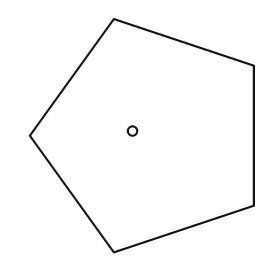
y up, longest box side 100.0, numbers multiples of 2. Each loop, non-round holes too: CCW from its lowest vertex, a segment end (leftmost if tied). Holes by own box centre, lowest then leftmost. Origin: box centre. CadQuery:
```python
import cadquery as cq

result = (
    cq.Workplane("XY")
    .moveTo(-12.0, -50.0)
    .lineTo(48.0, -30.0)
    .lineTo(48.0, 30.0)
    .lineTo(-12.0, 50.0)
    .lineTo(-48.0, 0.0)
    .close()
    .moveTo(-4.0, 2.0)
    .circle(2.0)
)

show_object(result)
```